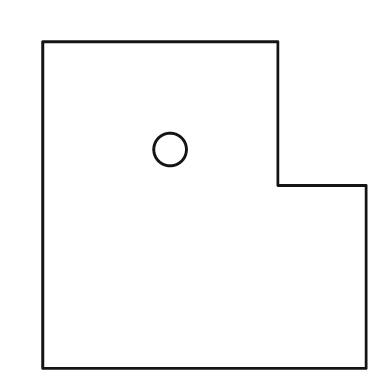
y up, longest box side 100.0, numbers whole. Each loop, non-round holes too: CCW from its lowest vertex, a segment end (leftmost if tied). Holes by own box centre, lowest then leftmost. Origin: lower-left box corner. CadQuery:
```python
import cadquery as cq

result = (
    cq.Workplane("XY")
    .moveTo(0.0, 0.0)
    .lineTo(99.0, 0.0)
    .lineTo(99.0, 56.0)
    .lineTo(72.0, 56.0)
    .lineTo(72.0, 100.0)
    .lineTo(0.0, 100.0)
    .close()
    .moveTo(39.0, 67.0)
    .circle(5.0)
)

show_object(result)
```